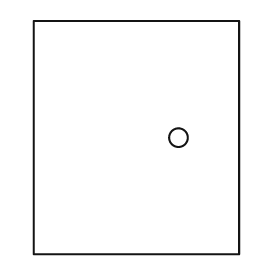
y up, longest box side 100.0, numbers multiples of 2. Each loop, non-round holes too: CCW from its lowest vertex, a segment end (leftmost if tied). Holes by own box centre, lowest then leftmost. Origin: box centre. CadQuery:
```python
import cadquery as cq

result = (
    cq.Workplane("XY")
    .moveTo(-44.0, -50.0)
    .lineTo(44.0, -50.0)
    .lineTo(44.0, 50.0)
    .lineTo(-44.0, 50.0)
    .close()
    .moveTo(18.0, 0.0)
    .circle(4.0)
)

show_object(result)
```